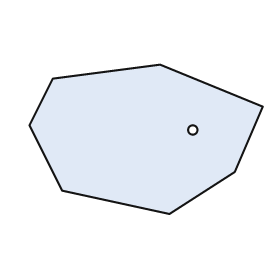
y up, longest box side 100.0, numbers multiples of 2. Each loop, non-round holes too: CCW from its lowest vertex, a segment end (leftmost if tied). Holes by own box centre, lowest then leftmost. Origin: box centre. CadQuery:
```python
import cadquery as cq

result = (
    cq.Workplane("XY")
    .moveTo(10.0, -32.0)
    .lineTo(38.0, -14.0)
    .lineTo(50.0, 14.0)
    .lineTo(6.0, 32.0)
    .lineTo(-40.0, 26.0)
    .lineTo(-50.0, 6.0)
    .lineTo(-36.0, -22.0)
    .close()
    .moveTo(20.0, 4.0)
    .circle(2.0)
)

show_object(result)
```